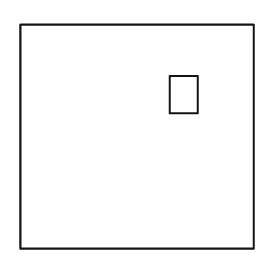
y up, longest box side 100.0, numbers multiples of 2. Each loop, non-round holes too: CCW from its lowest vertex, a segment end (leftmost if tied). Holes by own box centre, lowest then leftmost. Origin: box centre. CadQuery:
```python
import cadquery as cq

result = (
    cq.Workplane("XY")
    .moveTo(-50.0, -48.0)
    .lineTo(50.0, -48.0)
    .lineTo(50.0, 48.0)
    .lineTo(-50.0, 48.0)
    .close()
    .moveTo(14.0, 10.0)
    .lineTo(26.0, 10.0)
    .lineTo(26.0, 26.0)
    .lineTo(14.0, 26.0)
    .close()
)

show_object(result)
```